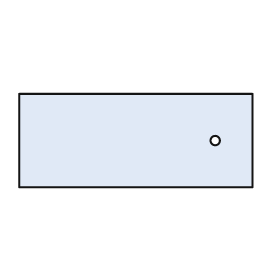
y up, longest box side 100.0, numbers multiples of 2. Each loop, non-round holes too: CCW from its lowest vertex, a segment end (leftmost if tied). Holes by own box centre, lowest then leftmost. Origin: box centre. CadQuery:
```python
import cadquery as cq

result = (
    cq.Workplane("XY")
    .moveTo(-50.0, -20.0)
    .lineTo(50.0, -20.0)
    .lineTo(50.0, 20.0)
    .lineTo(-50.0, 20.0)
    .close()
    .moveTo(34.0, 0.0)
    .circle(2.0)
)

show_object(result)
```